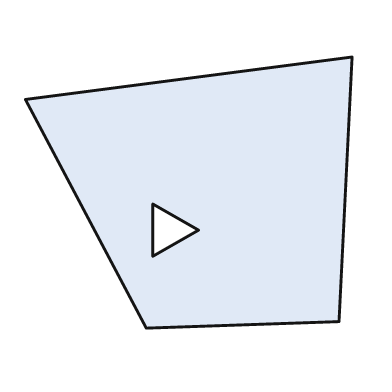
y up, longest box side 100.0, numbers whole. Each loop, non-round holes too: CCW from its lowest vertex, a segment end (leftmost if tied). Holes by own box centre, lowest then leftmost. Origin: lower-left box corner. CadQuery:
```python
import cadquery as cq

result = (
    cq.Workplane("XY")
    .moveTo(37.0, 0.0)
    .lineTo(96.0, 2.0)
    .lineTo(100.0, 83.0)
    .lineTo(0.0, 70.0)
    .close()
    .moveTo(39.0, 22.0)
    .lineTo(53.0, 30.0)
    .lineTo(39.0, 38.0)
    .close()
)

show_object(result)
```